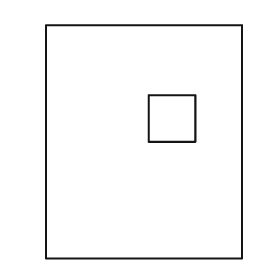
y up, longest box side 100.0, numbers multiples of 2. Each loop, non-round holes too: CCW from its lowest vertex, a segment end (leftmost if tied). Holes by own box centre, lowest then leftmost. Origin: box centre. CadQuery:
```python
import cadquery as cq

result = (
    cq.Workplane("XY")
    .moveTo(-42.0, -50.0)
    .lineTo(42.0, -50.0)
    .lineTo(42.0, 50.0)
    .lineTo(-42.0, 50.0)
    .close()
    .moveTo(2.0, 0.0)
    .lineTo(22.0, 0.0)
    .lineTo(22.0, 20.0)
    .lineTo(2.0, 20.0)
    .close()
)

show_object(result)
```